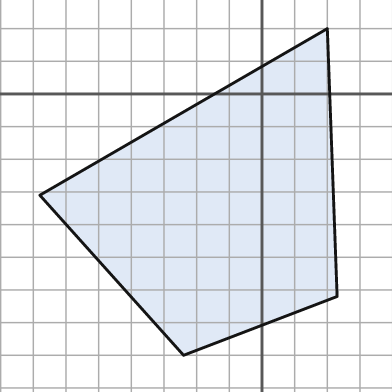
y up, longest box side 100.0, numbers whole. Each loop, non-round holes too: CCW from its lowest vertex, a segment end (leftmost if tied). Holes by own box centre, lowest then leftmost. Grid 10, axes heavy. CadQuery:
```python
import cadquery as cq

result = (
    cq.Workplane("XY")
    .moveTo(-24.0, -80.0)
    .lineTo(23.0, -62.0)
    .lineTo(20.0, 20.0)
    .lineTo(-68.0, -31.0)
    .close()
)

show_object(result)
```